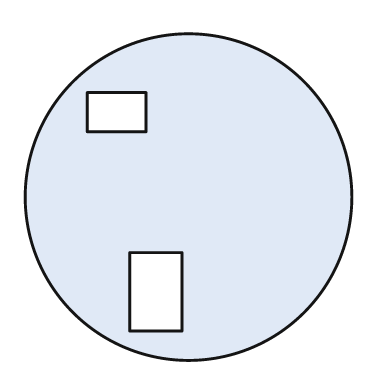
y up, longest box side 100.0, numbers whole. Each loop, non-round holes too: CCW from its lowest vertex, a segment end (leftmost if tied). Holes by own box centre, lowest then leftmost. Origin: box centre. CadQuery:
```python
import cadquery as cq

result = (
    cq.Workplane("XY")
    .moveTo(0.0, 0.0)
    .circle(50.0)
    .moveTo(-18.0, -41.0)
    .lineTo(-2.0, -41.0)
    .lineTo(-2.0, -17.0)
    .lineTo(-18.0, -17.0)
    .close()
    .moveTo(-31.0, 20.0)
    .lineTo(-13.0, 20.0)
    .lineTo(-13.0, 32.0)
    .lineTo(-31.0, 32.0)
    .close()
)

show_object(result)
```